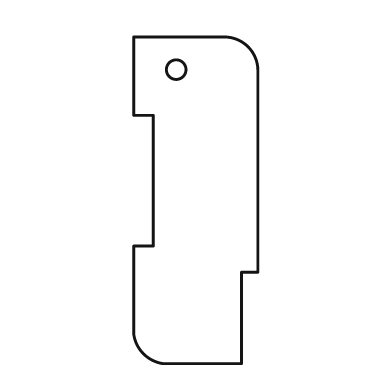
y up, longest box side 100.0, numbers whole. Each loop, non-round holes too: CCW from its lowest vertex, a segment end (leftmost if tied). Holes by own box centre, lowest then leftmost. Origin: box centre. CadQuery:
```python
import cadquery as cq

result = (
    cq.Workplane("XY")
    .moveTo(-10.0, -50.0)
    .lineTo(14.0, -50.0)
    .lineTo(14.0, -22.0)
    .lineTo(19.0, -22.0)
    .lineTo(19.0, 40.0)
    .threePointArc((16.0, 47.0), (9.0, 50.0))
    .lineTo(-19.0, 50.0)
    .lineTo(-19.0, 26.0)
    .lineTo(-13.0, 26.0)
    .lineTo(-13.0, -14.0)
    .lineTo(-19.0, -14.0)
    .lineTo(-19.0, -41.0)
    .threePointArc((-16.0, -47.0), (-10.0, -50.0))
    .close()
    .moveTo(-6.0, 40.0)
    .circle(3.0)
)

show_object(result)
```